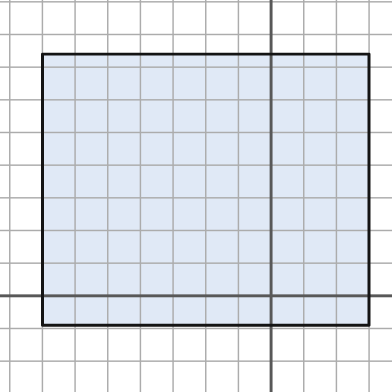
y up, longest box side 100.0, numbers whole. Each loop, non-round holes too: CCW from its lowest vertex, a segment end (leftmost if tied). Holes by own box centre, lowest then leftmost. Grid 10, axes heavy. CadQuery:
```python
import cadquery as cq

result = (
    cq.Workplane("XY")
    .moveTo(-70.0, -9.0)
    .lineTo(30.0, -9.0)
    .lineTo(30.0, 74.0)
    .lineTo(-70.0, 74.0)
    .close()
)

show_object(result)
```